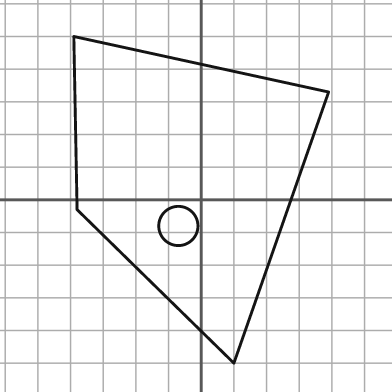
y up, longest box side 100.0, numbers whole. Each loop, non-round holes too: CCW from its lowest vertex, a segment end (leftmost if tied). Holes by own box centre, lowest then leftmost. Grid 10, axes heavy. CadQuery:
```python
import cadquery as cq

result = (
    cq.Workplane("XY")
    .moveTo(10.0, -50.0)
    .lineTo(39.0, 33.0)
    .lineTo(-39.0, 50.0)
    .lineTo(-38.0, -3.0)
    .close()
    .moveTo(-7.0, -8.0)
    .circle(6.0)
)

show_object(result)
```